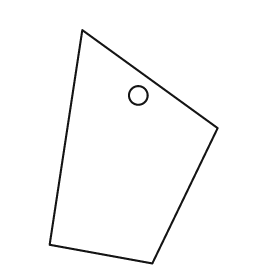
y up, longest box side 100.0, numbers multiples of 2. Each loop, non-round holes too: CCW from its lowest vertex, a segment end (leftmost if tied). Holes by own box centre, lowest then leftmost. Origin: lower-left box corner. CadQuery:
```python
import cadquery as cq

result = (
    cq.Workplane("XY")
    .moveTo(44.0, 0.0)
    .lineTo(72.0, 58.0)
    .lineTo(14.0, 100.0)
    .lineTo(0.0, 8.0)
    .close()
    .moveTo(38.0, 72.0)
    .circle(4.0)
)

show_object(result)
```